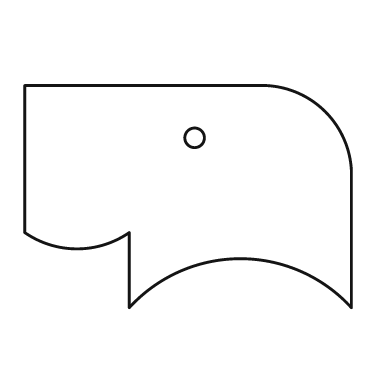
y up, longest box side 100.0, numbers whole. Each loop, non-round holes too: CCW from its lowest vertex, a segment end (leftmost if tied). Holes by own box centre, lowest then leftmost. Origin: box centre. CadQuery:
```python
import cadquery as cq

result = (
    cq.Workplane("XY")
    .moveTo(-18.0, -34.0)
    .threePointArc((16.0, -19.0), (50.0, -34.0))
    .lineTo(50.0, 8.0)
    .threePointArc((42.0, 26.0), (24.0, 34.0))
    .lineTo(-50.0, 34.0)
    .lineTo(-50.0, -11.0)
    .threePointArc((-34.0, -16.0), (-18.0, -11.0))
    .close()
    .moveTo(2.0, 18.0)
    .circle(3.0)
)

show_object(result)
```